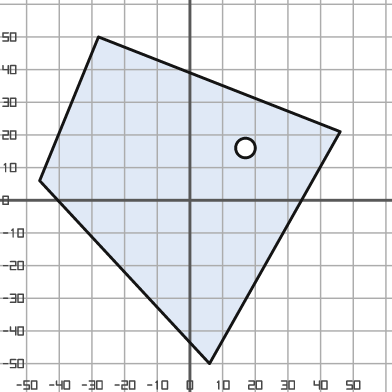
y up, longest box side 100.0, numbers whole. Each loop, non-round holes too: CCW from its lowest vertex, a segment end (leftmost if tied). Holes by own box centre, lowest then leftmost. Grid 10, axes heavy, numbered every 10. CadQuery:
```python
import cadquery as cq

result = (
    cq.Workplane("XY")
    .moveTo(6.0, -50.0)
    .lineTo(46.0, 21.0)
    .lineTo(-28.0, 50.0)
    .lineTo(-46.0, 6.0)
    .close()
    .moveTo(17.0, 16.0)
    .circle(3.0)
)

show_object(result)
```